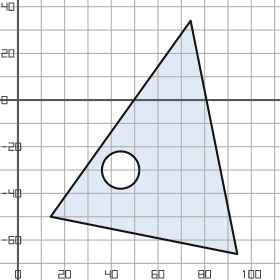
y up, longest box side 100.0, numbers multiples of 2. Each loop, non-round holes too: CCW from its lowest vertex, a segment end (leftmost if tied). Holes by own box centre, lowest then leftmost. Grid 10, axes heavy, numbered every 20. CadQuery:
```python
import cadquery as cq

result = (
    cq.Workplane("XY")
    .moveTo(94.0, -66.0)
    .lineTo(74.0, 34.0)
    .lineTo(14.0, -50.0)
    .close()
    .moveTo(44.0, -30.0)
    .circle(8.0)
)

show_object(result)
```